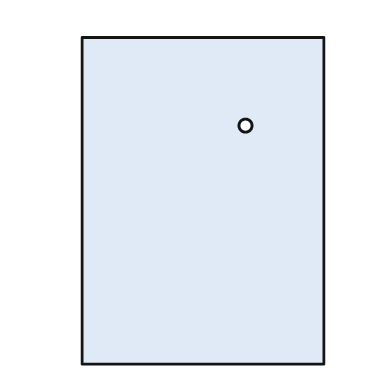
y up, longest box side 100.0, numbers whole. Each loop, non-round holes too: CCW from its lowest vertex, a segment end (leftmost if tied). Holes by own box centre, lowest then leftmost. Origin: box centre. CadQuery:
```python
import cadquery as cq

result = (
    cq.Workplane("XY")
    .moveTo(-37.0, -50.0)
    .lineTo(37.0, -50.0)
    .lineTo(37.0, 50.0)
    .lineTo(-37.0, 50.0)
    .close()
    .moveTo(13.0, 23.0)
    .circle(2.0)
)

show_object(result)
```